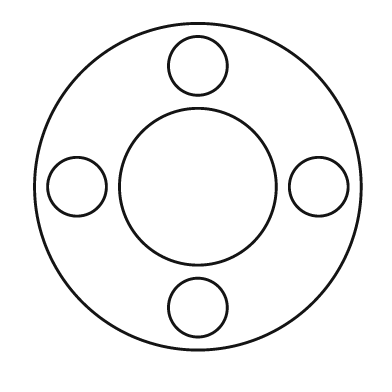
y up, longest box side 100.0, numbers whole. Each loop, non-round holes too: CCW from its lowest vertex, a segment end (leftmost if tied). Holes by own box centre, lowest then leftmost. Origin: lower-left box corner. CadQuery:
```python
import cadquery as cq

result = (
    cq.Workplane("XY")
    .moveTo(50.0, 50.0)
    .circle(50.0)
    .moveTo(50.0, 13.0)
    .circle(9.0)
    .moveTo(13.0, 50.0)
    .circle(9.0)
    .moveTo(50.0, 50.0)
    .circle(24.0)
    .moveTo(87.0, 50.0)
    .circle(9.0)
    .moveTo(50.0, 87.0)
    .circle(9.0)
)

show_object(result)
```